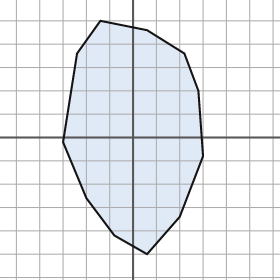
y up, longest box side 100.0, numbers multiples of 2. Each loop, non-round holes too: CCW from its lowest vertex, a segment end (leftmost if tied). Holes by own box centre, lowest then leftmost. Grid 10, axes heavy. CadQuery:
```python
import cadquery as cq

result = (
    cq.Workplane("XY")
    .moveTo(6.0, -50.0)
    .lineTo(20.0, -34.0)
    .lineTo(30.0, -8.0)
    .lineTo(28.0, 20.0)
    .lineTo(22.0, 36.0)
    .lineTo(6.0, 46.0)
    .lineTo(-14.0, 50.0)
    .lineTo(-24.0, 36.0)
    .lineTo(-30.0, -2.0)
    .lineTo(-20.0, -26.0)
    .lineTo(-8.0, -42.0)
    .close()
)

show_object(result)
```